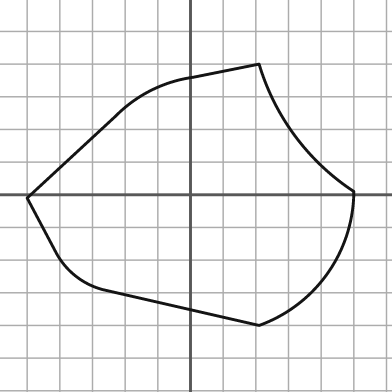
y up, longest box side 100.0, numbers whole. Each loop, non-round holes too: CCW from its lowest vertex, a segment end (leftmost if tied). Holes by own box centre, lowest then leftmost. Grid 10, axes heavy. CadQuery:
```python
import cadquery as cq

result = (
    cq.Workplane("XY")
    .moveTo(21.0, -40.0)
    .threePointArc((42.0, -24.0), (50.0, 1.0))
    .threePointArc((32.0, 18.0), (21.0, 40.0))
    .lineTo(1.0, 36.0)
    .threePointArc((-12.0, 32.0), (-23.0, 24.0))
    .lineTo(-50.0, -1.0)
    .lineTo(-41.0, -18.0)
    .threePointArc((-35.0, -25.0), (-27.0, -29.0))
    .close()
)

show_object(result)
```